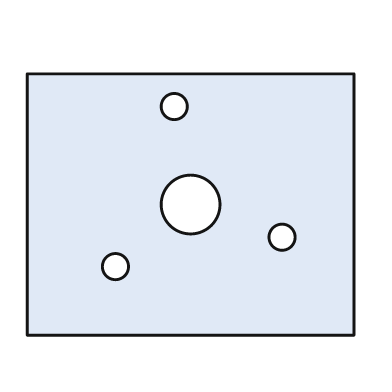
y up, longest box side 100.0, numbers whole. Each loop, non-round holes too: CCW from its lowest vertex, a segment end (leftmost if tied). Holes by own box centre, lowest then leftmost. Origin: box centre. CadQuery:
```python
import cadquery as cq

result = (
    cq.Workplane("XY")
    .moveTo(-50.0, -40.0)
    .lineTo(50.0, -40.0)
    .lineTo(50.0, 40.0)
    .lineTo(-50.0, 40.0)
    .close()
    .moveTo(-23.0, -19.0)
    .circle(4.0)
    .moveTo(28.0, -10.0)
    .circle(4.0)
    .moveTo(0.0, 0.0)
    .circle(9.0)
    .moveTo(-5.0, 30.0)
    .circle(4.0)
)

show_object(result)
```